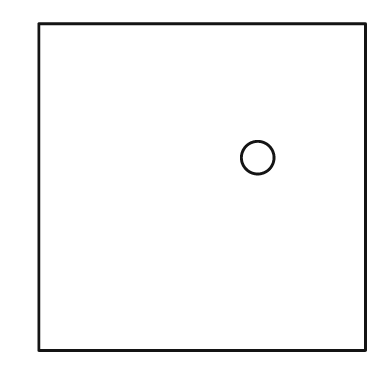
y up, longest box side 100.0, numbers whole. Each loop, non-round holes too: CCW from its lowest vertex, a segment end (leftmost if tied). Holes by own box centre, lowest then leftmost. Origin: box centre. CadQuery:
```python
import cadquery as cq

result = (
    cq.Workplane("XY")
    .moveTo(-50.0, -50.0)
    .lineTo(50.0, -50.0)
    .lineTo(50.0, 50.0)
    .lineTo(-50.0, 50.0)
    .close()
    .moveTo(17.0, 9.0)
    .circle(5.0)
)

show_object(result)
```